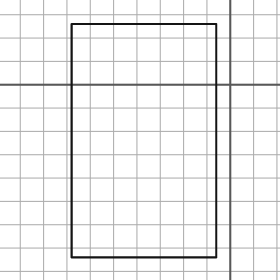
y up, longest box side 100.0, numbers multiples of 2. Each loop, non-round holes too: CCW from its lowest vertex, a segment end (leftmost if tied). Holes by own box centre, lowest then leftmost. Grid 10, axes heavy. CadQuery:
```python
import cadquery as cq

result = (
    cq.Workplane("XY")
    .moveTo(-68.0, -74.0)
    .lineTo(-6.0, -74.0)
    .lineTo(-6.0, 26.0)
    .lineTo(-68.0, 26.0)
    .close()
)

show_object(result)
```